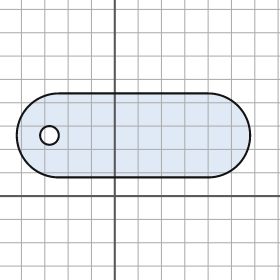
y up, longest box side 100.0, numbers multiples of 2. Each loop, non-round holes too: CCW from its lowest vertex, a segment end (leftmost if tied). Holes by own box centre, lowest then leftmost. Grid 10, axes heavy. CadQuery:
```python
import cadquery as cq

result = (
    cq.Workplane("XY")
    .moveTo(-24.0, 8.0)
    .lineTo(40.0, 8.0)
    .threePointArc((58.0, 26.0), (40.0, 44.0))
    .lineTo(-24.0, 44.0)
    .threePointArc((-42.0, 26.0), (-24.0, 8.0))
    .close()
    .moveTo(-28.0, 26.0)
    .circle(4.0)
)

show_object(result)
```